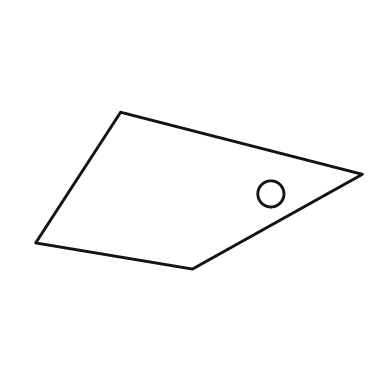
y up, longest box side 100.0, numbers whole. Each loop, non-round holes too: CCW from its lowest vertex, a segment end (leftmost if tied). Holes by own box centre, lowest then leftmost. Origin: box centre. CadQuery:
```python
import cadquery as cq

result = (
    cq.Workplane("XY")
    .moveTo(-2.0, -24.0)
    .lineTo(50.0, 5.0)
    .lineTo(-24.0, 24.0)
    .lineTo(-50.0, -16.0)
    .close()
    .moveTo(22.0, -1.0)
    .circle(4.0)
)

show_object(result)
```